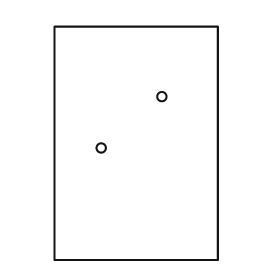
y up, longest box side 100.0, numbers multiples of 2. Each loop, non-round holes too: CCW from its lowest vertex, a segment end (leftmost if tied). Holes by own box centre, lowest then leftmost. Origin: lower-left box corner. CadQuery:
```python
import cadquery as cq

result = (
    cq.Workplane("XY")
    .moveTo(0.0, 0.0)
    .lineTo(70.0, 0.0)
    .lineTo(70.0, 100.0)
    .lineTo(0.0, 100.0)
    .close()
    .moveTo(20.0, 48.0)
    .circle(2.0)
    .moveTo(46.0, 70.0)
    .circle(2.0)
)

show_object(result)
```